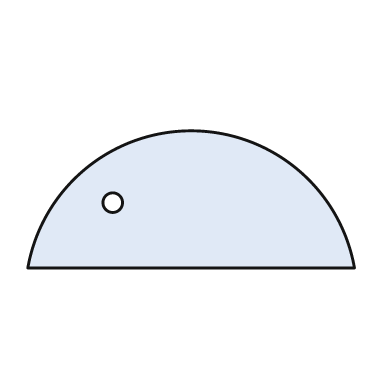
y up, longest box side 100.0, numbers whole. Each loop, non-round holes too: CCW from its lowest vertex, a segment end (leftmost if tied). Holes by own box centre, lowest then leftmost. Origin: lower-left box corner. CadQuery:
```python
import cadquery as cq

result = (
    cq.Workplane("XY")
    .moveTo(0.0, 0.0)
    .lineTo(100.0, 0.0)
    .threePointArc((50.0, 42.0), (0.0, 0.0))
    .close()
    .moveTo(26.0, 20.0)
    .circle(3.0)
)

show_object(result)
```